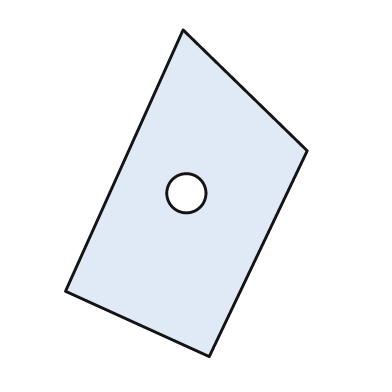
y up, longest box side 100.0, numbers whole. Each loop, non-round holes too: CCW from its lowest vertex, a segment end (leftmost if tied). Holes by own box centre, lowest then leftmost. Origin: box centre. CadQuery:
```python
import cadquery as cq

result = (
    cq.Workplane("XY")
    .moveTo(7.0, -50.0)
    .lineTo(37.0, 13.0)
    .lineTo(-1.0, 50.0)
    .lineTo(-37.0, -30.0)
    .close()
    .moveTo(0.0, 0.0)
    .circle(6.0)
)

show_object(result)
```